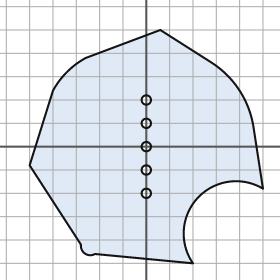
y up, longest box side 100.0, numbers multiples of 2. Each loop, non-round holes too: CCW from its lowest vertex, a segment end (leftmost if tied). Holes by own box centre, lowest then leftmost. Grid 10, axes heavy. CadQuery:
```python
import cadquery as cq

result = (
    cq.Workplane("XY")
    .moveTo(20.0, -50.0)
    .threePointArc((22.0, -22.0), (50.0, -18.0))
    .lineTo(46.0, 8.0)
    .threePointArc((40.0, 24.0), (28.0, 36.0))
    .lineTo(6.0, 50.0)
    .lineTo(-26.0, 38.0)
    .threePointArc((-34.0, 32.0), (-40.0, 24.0))
    .lineTo(-50.0, -8.0)
    .lineTo(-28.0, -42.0)
    .threePointArc((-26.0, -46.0), (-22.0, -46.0))
    .close()
    .moveTo(0.0, -20.0)
    .circle(2.0)
    .moveTo(0.0, -10.0)
    .circle(2.0)
    .moveTo(0.0, 0.0)
    .circle(2.0)
    .moveTo(0.0, 10.0)
    .circle(2.0)
    .moveTo(0.0, 20.0)
    .circle(2.0)
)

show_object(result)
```